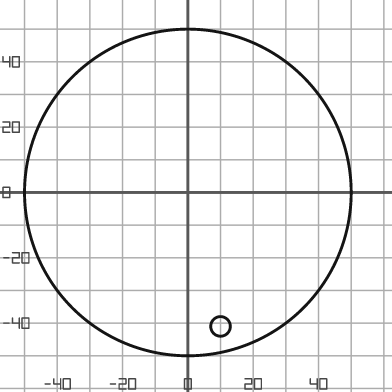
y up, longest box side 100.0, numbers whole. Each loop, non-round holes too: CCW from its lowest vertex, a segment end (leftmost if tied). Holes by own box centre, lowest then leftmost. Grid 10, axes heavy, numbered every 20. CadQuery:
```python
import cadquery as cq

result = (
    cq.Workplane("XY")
    .moveTo(0.0, 0.0)
    .circle(50.0)
    .moveTo(10.0, -41.0)
    .circle(3.0)
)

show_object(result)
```